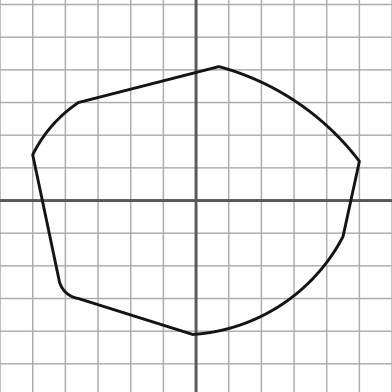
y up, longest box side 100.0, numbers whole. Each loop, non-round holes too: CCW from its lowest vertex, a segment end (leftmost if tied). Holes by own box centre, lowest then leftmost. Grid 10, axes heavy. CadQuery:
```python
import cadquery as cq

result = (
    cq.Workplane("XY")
    .moveTo(-1.0, -41.0)
    .threePointArc((26.0, -32.0), (45.0, -11.0))
    .lineTo(50.0, 12.0)
    .threePointArc((31.0, 30.0), (7.0, 41.0))
    .lineTo(-36.0, 30.0)
    .threePointArc((-44.0, 23.0), (-50.0, 14.0))
    .lineTo(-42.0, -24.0)
    .threePointArc((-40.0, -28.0), (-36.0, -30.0))
    .close()
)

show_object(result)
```